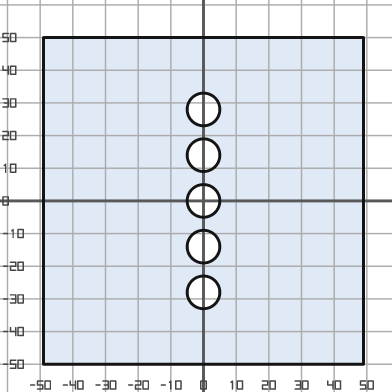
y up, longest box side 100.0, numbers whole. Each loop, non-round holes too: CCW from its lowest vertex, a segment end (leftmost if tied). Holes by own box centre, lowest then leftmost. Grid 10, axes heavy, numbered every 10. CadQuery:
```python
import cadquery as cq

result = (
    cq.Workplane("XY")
    .moveTo(-49.0, -50.0)
    .lineTo(49.0, -50.0)
    .lineTo(49.0, 50.0)
    .lineTo(-49.0, 50.0)
    .close()
    .moveTo(0.0, -28.0)
    .circle(5.0)
    .moveTo(0.0, -14.0)
    .circle(5.0)
    .moveTo(0.0, 0.0)
    .circle(5.0)
    .moveTo(0.0, 14.0)
    .circle(5.0)
    .moveTo(0.0, 28.0)
    .circle(5.0)
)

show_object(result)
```